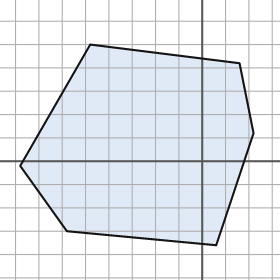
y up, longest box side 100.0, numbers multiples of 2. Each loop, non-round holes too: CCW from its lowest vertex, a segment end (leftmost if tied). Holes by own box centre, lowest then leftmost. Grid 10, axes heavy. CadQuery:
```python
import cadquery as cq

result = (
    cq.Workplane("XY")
    .moveTo(6.0, -36.0)
    .lineTo(22.0, 12.0)
    .lineTo(16.0, 42.0)
    .lineTo(-48.0, 50.0)
    .lineTo(-78.0, -2.0)
    .lineTo(-58.0, -30.0)
    .close()
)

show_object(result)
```